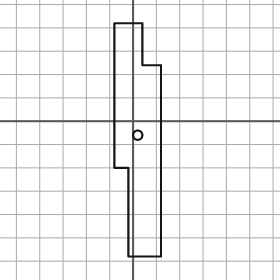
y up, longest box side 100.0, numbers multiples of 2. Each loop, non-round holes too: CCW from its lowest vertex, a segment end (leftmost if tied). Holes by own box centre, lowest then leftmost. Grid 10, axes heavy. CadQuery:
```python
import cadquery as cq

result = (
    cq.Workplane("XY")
    .moveTo(-2.0, -58.0)
    .lineTo(12.0, -58.0)
    .lineTo(12.0, 24.0)
    .lineTo(4.0, 24.0)
    .lineTo(4.0, 42.0)
    .lineTo(-8.0, 42.0)
    .lineTo(-8.0, -20.0)
    .lineTo(-2.0, -20.0)
    .close()
    .moveTo(2.0, -6.0)
    .circle(2.0)
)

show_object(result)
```